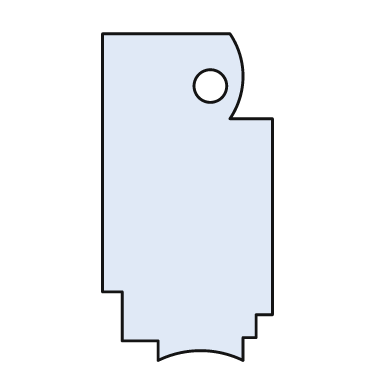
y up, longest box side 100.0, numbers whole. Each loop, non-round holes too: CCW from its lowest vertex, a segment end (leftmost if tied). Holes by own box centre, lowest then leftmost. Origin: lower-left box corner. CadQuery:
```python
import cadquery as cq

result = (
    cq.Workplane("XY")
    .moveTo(17.0, 0.0)
    .threePointArc((30.0, 3.0), (43.0, 0.0))
    .lineTo(43.0, 7.0)
    .lineTo(47.0, 7.0)
    .lineTo(47.0, 14.0)
    .lineTo(52.0, 14.0)
    .lineTo(52.0, 74.0)
    .lineTo(39.0, 74.0)
    .threePointArc((43.0, 87.0), (39.0, 100.0))
    .lineTo(0.0, 100.0)
    .lineTo(0.0, 21.0)
    .lineTo(6.0, 21.0)
    .lineTo(6.0, 6.0)
    .lineTo(17.0, 6.0)
    .close()
    .moveTo(33.0, 84.0)
    .circle(5.0)
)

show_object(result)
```